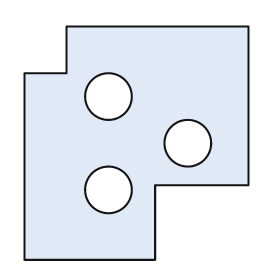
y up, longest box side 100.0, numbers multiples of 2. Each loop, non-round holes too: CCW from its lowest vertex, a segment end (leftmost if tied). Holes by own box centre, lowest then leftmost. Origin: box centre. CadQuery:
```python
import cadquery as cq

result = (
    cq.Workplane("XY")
    .moveTo(-48.0, -50.0)
    .lineTo(8.0, -50.0)
    .lineTo(8.0, -18.0)
    .lineTo(48.0, -18.0)
    .lineTo(48.0, 50.0)
    .lineTo(-30.0, 50.0)
    .lineTo(-30.0, 30.0)
    .lineTo(-48.0, 30.0)
    .close()
    .moveTo(-12.0, -20.0)
    .circle(10.0)
    .moveTo(22.0, 0.0)
    .circle(10.0)
    .moveTo(-12.0, 20.0)
    .circle(10.0)
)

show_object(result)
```